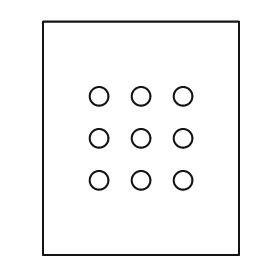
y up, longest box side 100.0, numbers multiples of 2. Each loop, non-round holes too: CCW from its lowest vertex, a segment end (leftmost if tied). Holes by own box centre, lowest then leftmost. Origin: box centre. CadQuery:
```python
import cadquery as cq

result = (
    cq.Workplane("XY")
    .moveTo(-42.0, -50.0)
    .lineTo(42.0, -50.0)
    .lineTo(42.0, 50.0)
    .lineTo(-42.0, 50.0)
    .close()
    .moveTo(-18.0, -18.0)
    .circle(4.0)
    .moveTo(0.0, -18.0)
    .circle(4.0)
    .moveTo(18.0, -18.0)
    .circle(4.0)
    .moveTo(-18.0, 0.0)
    .circle(4.0)
    .moveTo(0.0, 0.0)
    .circle(4.0)
    .moveTo(18.0, 0.0)
    .circle(4.0)
    .moveTo(-18.0, 18.0)
    .circle(4.0)
    .moveTo(0.0, 18.0)
    .circle(4.0)
    .moveTo(18.0, 18.0)
    .circle(4.0)
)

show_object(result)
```